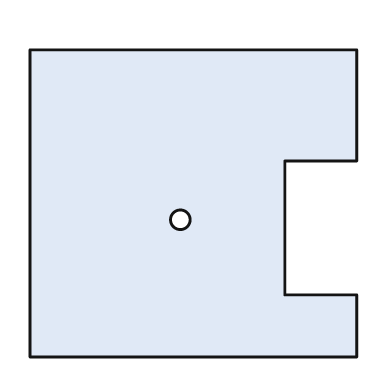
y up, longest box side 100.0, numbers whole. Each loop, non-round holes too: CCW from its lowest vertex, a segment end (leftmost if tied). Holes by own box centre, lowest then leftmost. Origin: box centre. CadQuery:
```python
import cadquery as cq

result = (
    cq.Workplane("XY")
    .moveTo(-50.0, -47.0)
    .lineTo(50.0, -47.0)
    .lineTo(50.0, -28.0)
    .lineTo(28.0, -28.0)
    .lineTo(28.0, 13.0)
    .lineTo(50.0, 13.0)
    .lineTo(50.0, 47.0)
    .lineTo(-50.0, 47.0)
    .close()
    .moveTo(-4.0, -5.0)
    .circle(3.0)
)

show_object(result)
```